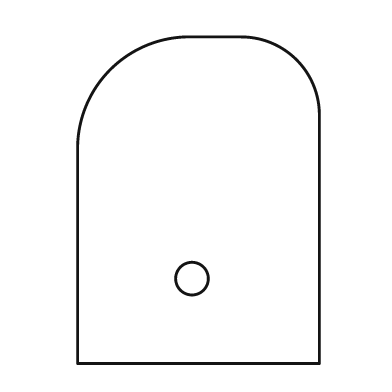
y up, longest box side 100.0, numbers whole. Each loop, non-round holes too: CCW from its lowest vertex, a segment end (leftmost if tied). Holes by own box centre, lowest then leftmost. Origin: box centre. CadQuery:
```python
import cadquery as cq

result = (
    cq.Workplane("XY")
    .moveTo(-37.0, -50.0)
    .lineTo(37.0, -50.0)
    .lineTo(37.0, 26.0)
    .threePointArc((30.0, 43.0), (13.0, 50.0))
    .lineTo(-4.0, 50.0)
    .threePointArc((-27.0, 40.0), (-37.0, 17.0))
    .close()
    .moveTo(-2.0, -24.0)
    .circle(5.0)
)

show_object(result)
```